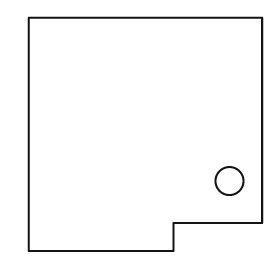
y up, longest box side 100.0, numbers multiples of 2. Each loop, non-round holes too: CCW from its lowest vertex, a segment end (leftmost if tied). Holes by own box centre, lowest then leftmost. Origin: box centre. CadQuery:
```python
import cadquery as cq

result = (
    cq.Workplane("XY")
    .moveTo(-50.0, -50.0)
    .lineTo(12.0, -50.0)
    .lineTo(12.0, -38.0)
    .lineTo(50.0, -38.0)
    .lineTo(50.0, 50.0)
    .lineTo(-50.0, 50.0)
    .close()
    .moveTo(36.0, -20.0)
    .circle(6.0)
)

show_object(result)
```